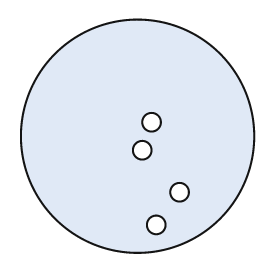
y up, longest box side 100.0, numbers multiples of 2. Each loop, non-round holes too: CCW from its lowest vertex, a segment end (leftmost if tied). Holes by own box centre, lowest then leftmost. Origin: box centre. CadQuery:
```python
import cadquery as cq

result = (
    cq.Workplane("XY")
    .moveTo(0.0, 0.0)
    .circle(50.0)
    .moveTo(8.0, -38.0)
    .circle(4.0)
    .moveTo(18.0, -24.0)
    .circle(4.0)
    .moveTo(2.0, -6.0)
    .circle(4.0)
    .moveTo(6.0, 6.0)
    .circle(4.0)
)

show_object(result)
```